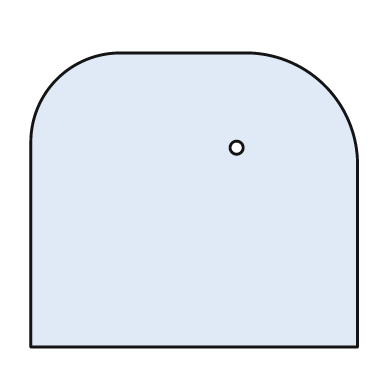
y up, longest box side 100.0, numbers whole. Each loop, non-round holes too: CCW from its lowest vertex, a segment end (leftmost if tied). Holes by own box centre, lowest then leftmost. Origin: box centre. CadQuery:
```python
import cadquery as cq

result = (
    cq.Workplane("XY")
    .moveTo(-50.0, -45.0)
    .lineTo(50.0, -45.0)
    .lineTo(50.0, 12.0)
    .threePointArc((40.0, 35.0), (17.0, 45.0))
    .lineTo(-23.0, 45.0)
    .threePointArc((-42.0, 37.0), (-50.0, 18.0))
    .close()
    .moveTo(13.0, 16.0)
    .circle(2.0)
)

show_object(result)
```